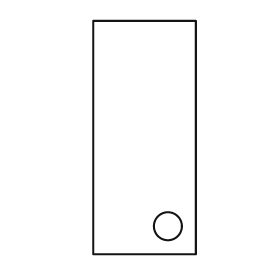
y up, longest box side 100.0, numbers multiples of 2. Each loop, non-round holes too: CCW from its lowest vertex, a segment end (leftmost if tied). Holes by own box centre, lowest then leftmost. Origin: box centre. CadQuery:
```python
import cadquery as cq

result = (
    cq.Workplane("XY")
    .moveTo(-22.0, -50.0)
    .lineTo(22.0, -50.0)
    .lineTo(22.0, 50.0)
    .lineTo(-22.0, 50.0)
    .close()
    .moveTo(10.0, -38.0)
    .circle(6.0)
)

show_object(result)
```